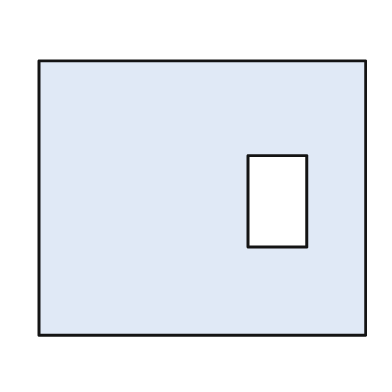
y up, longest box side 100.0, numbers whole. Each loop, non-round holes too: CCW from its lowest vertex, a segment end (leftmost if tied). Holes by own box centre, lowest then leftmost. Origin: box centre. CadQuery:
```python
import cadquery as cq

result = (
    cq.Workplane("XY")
    .moveTo(-50.0, -42.0)
    .lineTo(50.0, -42.0)
    .lineTo(50.0, 42.0)
    .lineTo(-50.0, 42.0)
    .close()
    .moveTo(14.0, -15.0)
    .lineTo(32.0, -15.0)
    .lineTo(32.0, 13.0)
    .lineTo(14.0, 13.0)
    .close()
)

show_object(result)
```